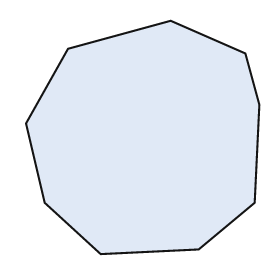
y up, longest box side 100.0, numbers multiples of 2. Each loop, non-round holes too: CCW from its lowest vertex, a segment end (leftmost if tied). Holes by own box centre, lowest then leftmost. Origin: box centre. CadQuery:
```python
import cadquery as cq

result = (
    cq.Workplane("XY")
    .moveTo(-18.0, -50.0)
    .lineTo(24.0, -48.0)
    .lineTo(48.0, -28.0)
    .lineTo(50.0, 14.0)
    .lineTo(44.0, 36.0)
    .lineTo(12.0, 50.0)
    .lineTo(-32.0, 38.0)
    .lineTo(-50.0, 6.0)
    .lineTo(-42.0, -28.0)
    .close()
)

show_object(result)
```